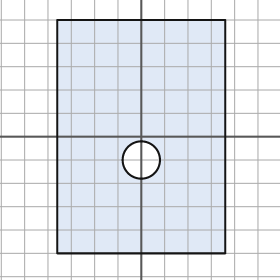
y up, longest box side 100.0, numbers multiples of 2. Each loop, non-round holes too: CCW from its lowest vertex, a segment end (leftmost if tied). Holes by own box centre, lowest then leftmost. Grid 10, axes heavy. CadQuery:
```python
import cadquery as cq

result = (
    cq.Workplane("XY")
    .moveTo(-36.0, -50.0)
    .lineTo(36.0, -50.0)
    .lineTo(36.0, 50.0)
    .lineTo(-36.0, 50.0)
    .close()
    .moveTo(0.0, -10.0)
    .circle(8.0)
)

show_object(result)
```